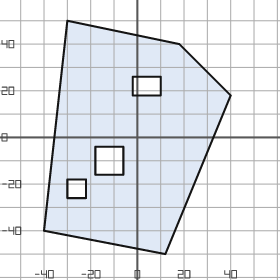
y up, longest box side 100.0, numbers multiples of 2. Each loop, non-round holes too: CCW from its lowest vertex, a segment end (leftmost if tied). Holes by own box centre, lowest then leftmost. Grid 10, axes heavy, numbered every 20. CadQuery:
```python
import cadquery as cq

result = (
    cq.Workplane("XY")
    .moveTo(12.0, -50.0)
    .lineTo(40.0, 18.0)
    .lineTo(18.0, 40.0)
    .lineTo(-30.0, 50.0)
    .lineTo(-40.0, -40.0)
    .close()
    .moveTo(-30.0, -26.0)
    .lineTo(-22.0, -26.0)
    .lineTo(-22.0, -18.0)
    .lineTo(-30.0, -18.0)
    .close()
    .moveTo(-18.0, -16.0)
    .lineTo(-6.0, -16.0)
    .lineTo(-6.0, -4.0)
    .lineTo(-18.0, -4.0)
    .close()
    .moveTo(-2.0, 18.0)
    .lineTo(10.0, 18.0)
    .lineTo(10.0, 26.0)
    .lineTo(-2.0, 26.0)
    .close()
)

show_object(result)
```